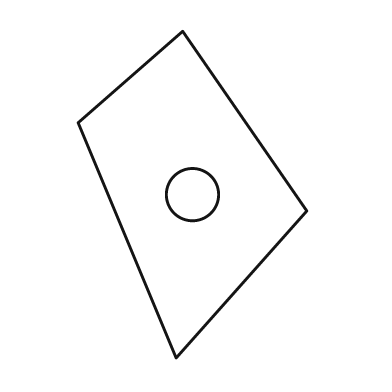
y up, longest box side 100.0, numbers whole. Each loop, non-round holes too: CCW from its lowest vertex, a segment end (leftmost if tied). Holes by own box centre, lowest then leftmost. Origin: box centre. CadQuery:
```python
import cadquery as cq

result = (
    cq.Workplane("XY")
    .moveTo(-5.0, -50.0)
    .lineTo(35.0, -5.0)
    .lineTo(-3.0, 50.0)
    .lineTo(-35.0, 22.0)
    .close()
    .moveTo(0.0, 0.0)
    .circle(8.0)
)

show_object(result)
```